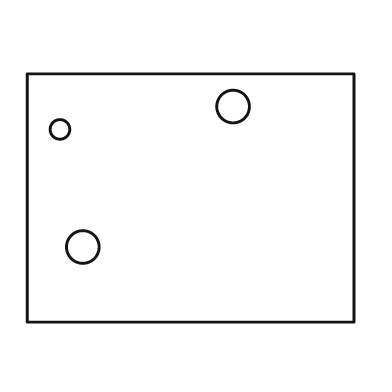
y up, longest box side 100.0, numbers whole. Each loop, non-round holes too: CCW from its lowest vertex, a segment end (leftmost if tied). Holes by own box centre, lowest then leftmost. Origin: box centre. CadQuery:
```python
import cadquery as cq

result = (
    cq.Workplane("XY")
    .moveTo(-50.0, -38.0)
    .lineTo(50.0, -38.0)
    .lineTo(50.0, 38.0)
    .lineTo(-50.0, 38.0)
    .close()
    .moveTo(-33.0, -15.0)
    .circle(5.0)
    .moveTo(-40.0, 21.0)
    .circle(3.0)
    .moveTo(13.0, 28.0)
    .circle(5.0)
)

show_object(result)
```